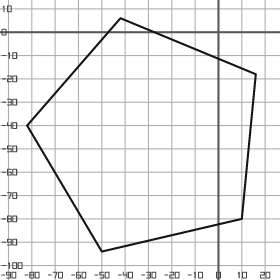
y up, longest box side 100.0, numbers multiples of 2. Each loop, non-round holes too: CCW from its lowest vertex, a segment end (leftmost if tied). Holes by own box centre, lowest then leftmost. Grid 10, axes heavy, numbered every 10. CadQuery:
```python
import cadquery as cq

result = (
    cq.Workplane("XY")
    .moveTo(-50.0, -94.0)
    .lineTo(10.0, -80.0)
    .lineTo(16.0, -18.0)
    .lineTo(-42.0, 6.0)
    .lineTo(-82.0, -40.0)
    .close()
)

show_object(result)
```